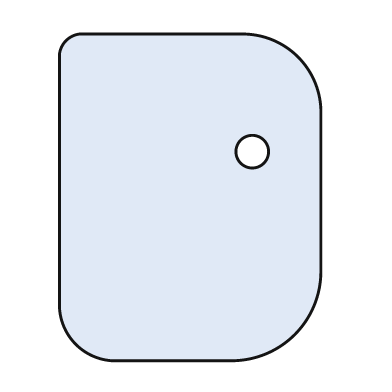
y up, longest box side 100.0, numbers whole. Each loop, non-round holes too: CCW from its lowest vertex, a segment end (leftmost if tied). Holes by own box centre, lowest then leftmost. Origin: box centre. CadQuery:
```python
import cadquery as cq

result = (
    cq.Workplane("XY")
    .moveTo(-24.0, -50.0)
    .lineTo(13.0, -50.0)
    .threePointArc((32.0, -42.0), (40.0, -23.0))
    .lineTo(40.0, 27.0)
    .threePointArc((33.0, 43.0), (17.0, 50.0))
    .lineTo(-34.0, 50.0)
    .threePointArc((-38.0, 48.0), (-40.0, 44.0))
    .lineTo(-40.0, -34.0)
    .threePointArc((-35.0, -45.0), (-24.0, -50.0))
    .close()
    .moveTo(19.0, 14.0)
    .circle(5.0)
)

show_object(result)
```